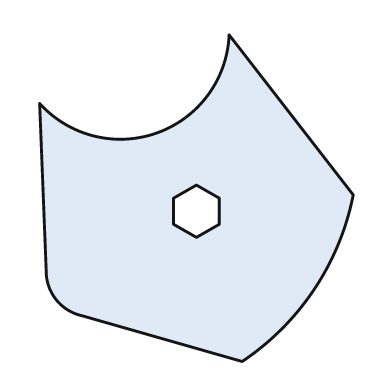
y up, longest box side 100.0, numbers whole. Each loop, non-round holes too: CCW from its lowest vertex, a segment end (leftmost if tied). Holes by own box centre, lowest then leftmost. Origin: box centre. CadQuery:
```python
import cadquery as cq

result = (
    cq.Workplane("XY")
    .moveTo(14.0, -50.0)
    .threePointArc((36.0, -28.0), (48.0, 1.0))
    .lineTo(10.0, 50.0)
    .threePointArc((-12.0, 20.0), (-48.0, 29.0))
    .lineTo(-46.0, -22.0)
    .threePointArc((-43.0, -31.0), (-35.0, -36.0))
    .close()
    .moveTo(0.0, -12.0)
    .lineTo(7.0, -8.0)
    .lineTo(7.0, 0.0)
    .lineTo(0.0, 4.0)
    .lineTo(-7.0, 0.0)
    .lineTo(-7.0, -8.0)
    .close()
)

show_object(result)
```